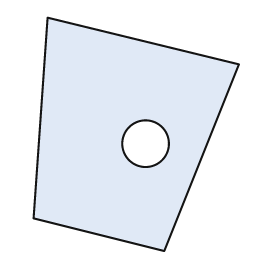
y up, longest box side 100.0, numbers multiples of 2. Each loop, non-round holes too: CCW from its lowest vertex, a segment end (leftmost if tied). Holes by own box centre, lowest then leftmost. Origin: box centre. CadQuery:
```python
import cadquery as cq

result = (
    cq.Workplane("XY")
    .moveTo(12.0, -50.0)
    .lineTo(44.0, 30.0)
    .lineTo(-38.0, 50.0)
    .lineTo(-44.0, -36.0)
    .close()
    .moveTo(4.0, -4.0)
    .circle(10.0)
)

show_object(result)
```